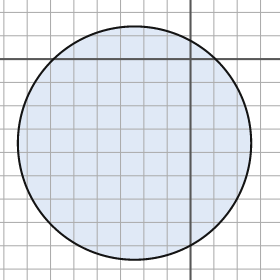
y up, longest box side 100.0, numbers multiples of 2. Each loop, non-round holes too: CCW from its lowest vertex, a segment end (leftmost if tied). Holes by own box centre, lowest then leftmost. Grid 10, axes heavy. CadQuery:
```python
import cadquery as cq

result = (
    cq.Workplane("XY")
    .moveTo(-24.0, -36.0)
    .circle(50.0)
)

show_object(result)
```